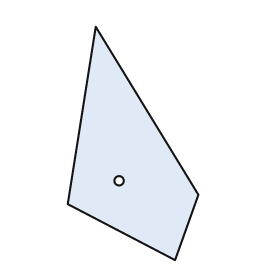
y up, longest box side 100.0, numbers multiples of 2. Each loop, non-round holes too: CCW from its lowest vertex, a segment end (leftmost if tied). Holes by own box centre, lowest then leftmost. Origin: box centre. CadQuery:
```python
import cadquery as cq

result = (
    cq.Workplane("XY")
    .moveTo(18.0, -50.0)
    .lineTo(28.0, -22.0)
    .lineTo(-16.0, 50.0)
    .lineTo(-28.0, -26.0)
    .close()
    .moveTo(-6.0, -16.0)
    .circle(2.0)
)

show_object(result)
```